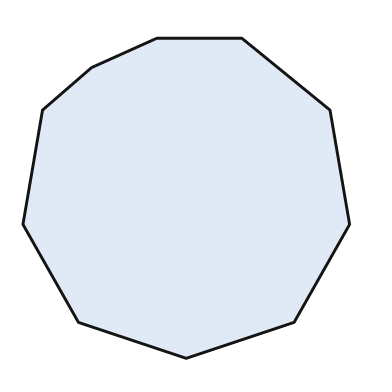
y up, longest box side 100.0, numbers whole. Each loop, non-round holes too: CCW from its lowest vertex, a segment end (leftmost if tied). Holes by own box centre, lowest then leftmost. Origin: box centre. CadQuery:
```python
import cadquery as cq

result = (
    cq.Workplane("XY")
    .moveTo(0.0, -49.0)
    .lineTo(33.0, -38.0)
    .lineTo(50.0, -8.0)
    .lineTo(44.0, 27.0)
    .lineTo(17.0, 49.0)
    .lineTo(-9.0, 49.0)
    .lineTo(-29.0, 40.0)
    .lineTo(-44.0, 27.0)
    .lineTo(-50.0, -8.0)
    .lineTo(-33.0, -38.0)
    .close()
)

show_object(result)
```